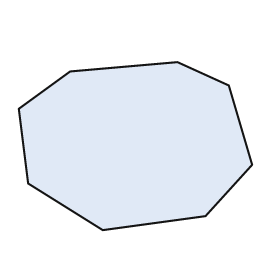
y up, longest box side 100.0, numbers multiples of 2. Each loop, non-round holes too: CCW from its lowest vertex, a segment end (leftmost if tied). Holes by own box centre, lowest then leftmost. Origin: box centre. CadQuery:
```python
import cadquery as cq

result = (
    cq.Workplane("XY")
    .moveTo(-14.0, -36.0)
    .lineTo(30.0, -30.0)
    .lineTo(50.0, -8.0)
    .lineTo(40.0, 26.0)
    .lineTo(18.0, 36.0)
    .lineTo(-28.0, 32.0)
    .lineTo(-50.0, 16.0)
    .lineTo(-46.0, -16.0)
    .close()
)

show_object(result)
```